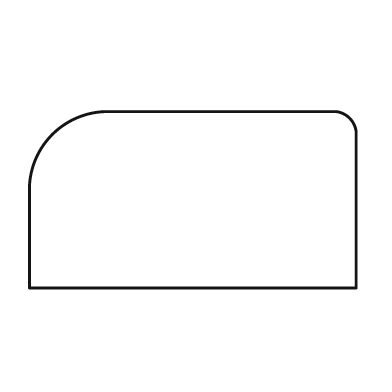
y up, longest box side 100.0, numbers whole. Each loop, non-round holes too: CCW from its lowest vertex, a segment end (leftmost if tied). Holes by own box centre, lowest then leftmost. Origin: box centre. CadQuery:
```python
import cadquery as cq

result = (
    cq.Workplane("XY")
    .moveTo(-50.0, -27.0)
    .lineTo(50.0, -27.0)
    .lineTo(50.0, 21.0)
    .threePointArc((48.0, 25.0), (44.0, 27.0))
    .lineTo(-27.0, 27.0)
    .threePointArc((-43.0, 20.0), (-50.0, 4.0))
    .close()
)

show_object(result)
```